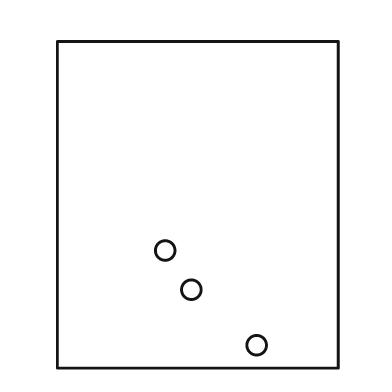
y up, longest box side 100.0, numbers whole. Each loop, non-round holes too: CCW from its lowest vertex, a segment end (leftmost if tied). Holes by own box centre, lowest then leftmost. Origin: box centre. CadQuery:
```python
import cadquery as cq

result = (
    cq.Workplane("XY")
    .moveTo(-43.0, -50.0)
    .lineTo(43.0, -50.0)
    .lineTo(43.0, 50.0)
    .lineTo(-43.0, 50.0)
    .close()
    .moveTo(18.0, -43.0)
    .circle(3.0)
    .moveTo(-2.0, -26.0)
    .circle(3.0)
    .moveTo(-10.0, -14.0)
    .circle(3.0)
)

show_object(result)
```